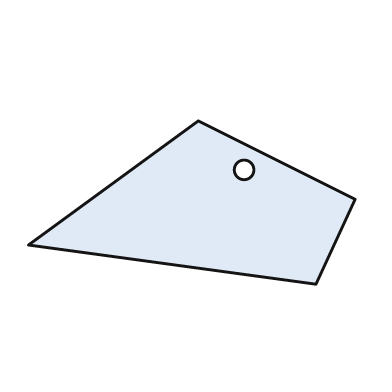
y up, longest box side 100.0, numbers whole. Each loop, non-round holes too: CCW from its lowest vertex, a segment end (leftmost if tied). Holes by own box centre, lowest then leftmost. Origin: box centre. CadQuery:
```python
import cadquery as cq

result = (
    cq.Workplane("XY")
    .moveTo(38.0, -25.0)
    .lineTo(50.0, 1.0)
    .lineTo(2.0, 25.0)
    .lineTo(-50.0, -13.0)
    .close()
    .moveTo(16.0, 10.0)
    .circle(3.0)
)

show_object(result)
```